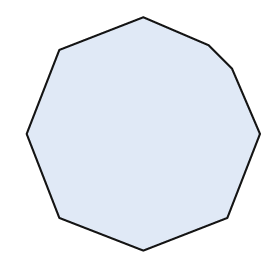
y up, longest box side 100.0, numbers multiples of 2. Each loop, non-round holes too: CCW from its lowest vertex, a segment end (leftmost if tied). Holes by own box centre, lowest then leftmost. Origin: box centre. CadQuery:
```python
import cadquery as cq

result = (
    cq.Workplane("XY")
    .moveTo(0.0, -50.0)
    .lineTo(36.0, -36.0)
    .lineTo(50.0, 0.0)
    .lineTo(38.0, 28.0)
    .lineTo(28.0, 38.0)
    .lineTo(0.0, 50.0)
    .lineTo(-36.0, 36.0)
    .lineTo(-50.0, 0.0)
    .lineTo(-36.0, -36.0)
    .close()
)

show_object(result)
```